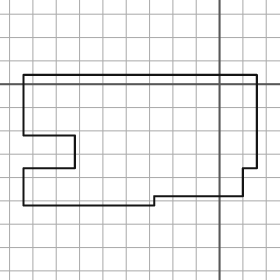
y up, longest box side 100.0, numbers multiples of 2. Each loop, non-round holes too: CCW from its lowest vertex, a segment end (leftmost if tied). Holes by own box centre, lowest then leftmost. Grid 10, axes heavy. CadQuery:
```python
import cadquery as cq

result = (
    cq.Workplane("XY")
    .moveTo(-84.0, -52.0)
    .lineTo(-28.0, -52.0)
    .lineTo(-28.0, -48.0)
    .lineTo(10.0, -48.0)
    .lineTo(10.0, -36.0)
    .lineTo(16.0, -36.0)
    .lineTo(16.0, 4.0)
    .lineTo(-84.0, 4.0)
    .lineTo(-84.0, -22.0)
    .lineTo(-62.0, -22.0)
    .lineTo(-62.0, -36.0)
    .lineTo(-84.0, -36.0)
    .close()
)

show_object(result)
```